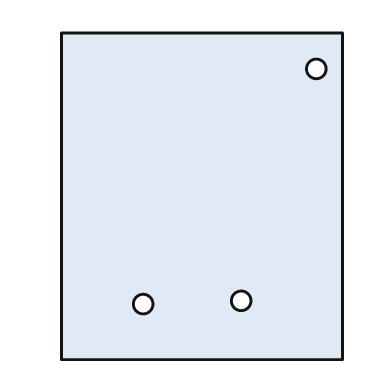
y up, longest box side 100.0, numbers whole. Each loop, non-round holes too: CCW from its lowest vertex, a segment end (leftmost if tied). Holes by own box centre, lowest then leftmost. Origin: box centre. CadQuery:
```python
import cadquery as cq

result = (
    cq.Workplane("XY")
    .moveTo(-43.0, -50.0)
    .lineTo(43.0, -50.0)
    .lineTo(43.0, 50.0)
    .lineTo(-43.0, 50.0)
    .close()
    .moveTo(-18.0, -33.0)
    .circle(3.0)
    .moveTo(12.0, -32.0)
    .circle(3.0)
    .moveTo(35.0, 39.0)
    .circle(3.0)
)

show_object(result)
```